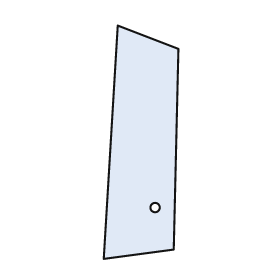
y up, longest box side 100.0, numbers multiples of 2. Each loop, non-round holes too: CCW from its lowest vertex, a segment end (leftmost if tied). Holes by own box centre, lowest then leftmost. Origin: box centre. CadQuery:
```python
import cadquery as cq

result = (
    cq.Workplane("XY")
    .moveTo(-16.0, -50.0)
    .lineTo(14.0, -46.0)
    .lineTo(16.0, 40.0)
    .lineTo(-10.0, 50.0)
    .close()
    .moveTo(6.0, -28.0)
    .circle(2.0)
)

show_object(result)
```